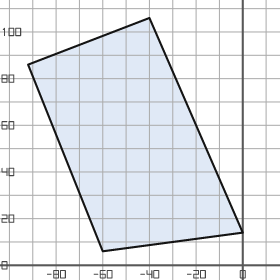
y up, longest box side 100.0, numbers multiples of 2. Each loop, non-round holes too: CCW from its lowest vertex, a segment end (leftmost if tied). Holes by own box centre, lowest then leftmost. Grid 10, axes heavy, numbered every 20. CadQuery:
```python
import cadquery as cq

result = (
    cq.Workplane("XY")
    .moveTo(-60.0, 6.0)
    .lineTo(0.0, 14.0)
    .lineTo(-40.0, 106.0)
    .lineTo(-92.0, 86.0)
    .close()
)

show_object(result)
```